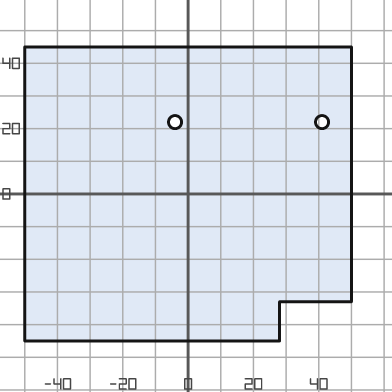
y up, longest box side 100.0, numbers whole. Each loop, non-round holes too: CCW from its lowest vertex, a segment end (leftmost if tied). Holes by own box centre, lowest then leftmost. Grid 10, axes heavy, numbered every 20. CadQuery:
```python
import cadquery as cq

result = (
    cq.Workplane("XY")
    .moveTo(-50.0, -45.0)
    .lineTo(28.0, -45.0)
    .lineTo(28.0, -33.0)
    .lineTo(50.0, -33.0)
    .lineTo(50.0, 45.0)
    .lineTo(-50.0, 45.0)
    .close()
    .moveTo(-4.0, 22.0)
    .circle(2.0)
    .moveTo(41.0, 22.0)
    .circle(2.0)
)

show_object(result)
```